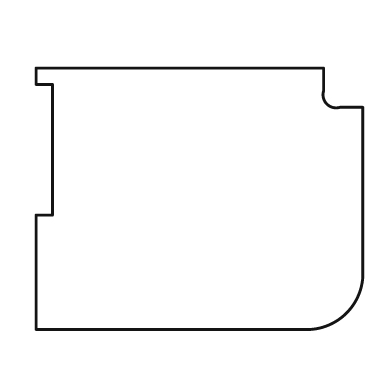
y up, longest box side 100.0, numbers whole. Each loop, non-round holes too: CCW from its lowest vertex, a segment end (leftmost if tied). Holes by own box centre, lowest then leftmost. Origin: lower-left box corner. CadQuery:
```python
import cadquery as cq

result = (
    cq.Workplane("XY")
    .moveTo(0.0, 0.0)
    .lineTo(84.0, 0.0)
    .threePointArc((95.0, 5.0), (100.0, 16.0))
    .lineTo(100.0, 68.0)
    .lineTo(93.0, 68.0)
    .threePointArc((89.0, 69.0), (88.0, 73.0))
    .lineTo(88.0, 80.0)
    .lineTo(0.0, 80.0)
    .lineTo(0.0, 75.0)
    .lineTo(5.0, 75.0)
    .lineTo(5.0, 35.0)
    .lineTo(0.0, 35.0)
    .close()
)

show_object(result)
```